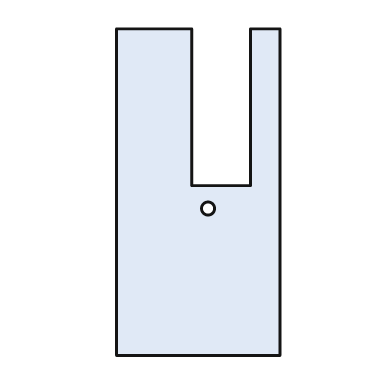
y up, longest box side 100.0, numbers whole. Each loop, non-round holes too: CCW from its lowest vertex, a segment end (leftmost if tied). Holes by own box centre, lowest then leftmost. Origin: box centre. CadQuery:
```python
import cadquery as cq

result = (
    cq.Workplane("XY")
    .moveTo(-25.0, -50.0)
    .lineTo(25.0, -50.0)
    .lineTo(25.0, 50.0)
    .lineTo(16.0, 50.0)
    .lineTo(16.0, 2.0)
    .lineTo(-2.0, 2.0)
    .lineTo(-2.0, 50.0)
    .lineTo(-25.0, 50.0)
    .close()
    .moveTo(3.0, -5.0)
    .circle(2.0)
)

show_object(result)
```